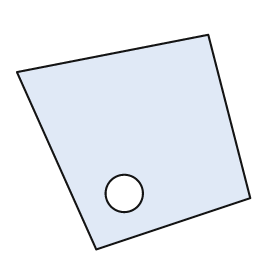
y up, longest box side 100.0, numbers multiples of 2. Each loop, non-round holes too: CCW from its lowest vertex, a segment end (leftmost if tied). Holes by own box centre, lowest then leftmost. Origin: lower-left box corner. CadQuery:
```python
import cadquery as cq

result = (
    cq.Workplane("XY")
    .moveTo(34.0, 0.0)
    .lineTo(100.0, 22.0)
    .lineTo(82.0, 92.0)
    .lineTo(0.0, 76.0)
    .close()
    .moveTo(46.0, 24.0)
    .circle(8.0)
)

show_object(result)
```